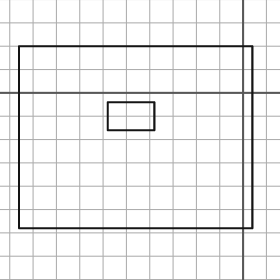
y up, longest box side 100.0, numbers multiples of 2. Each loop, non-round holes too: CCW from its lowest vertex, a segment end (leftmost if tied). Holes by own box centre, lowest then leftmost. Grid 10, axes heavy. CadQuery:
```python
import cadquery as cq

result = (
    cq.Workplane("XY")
    .moveTo(-96.0, -58.0)
    .lineTo(4.0, -58.0)
    .lineTo(4.0, 20.0)
    .lineTo(-96.0, 20.0)
    .close()
    .moveTo(-58.0, -16.0)
    .lineTo(-38.0, -16.0)
    .lineTo(-38.0, -4.0)
    .lineTo(-58.0, -4.0)
    .close()
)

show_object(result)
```